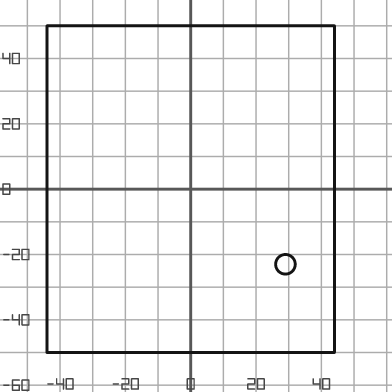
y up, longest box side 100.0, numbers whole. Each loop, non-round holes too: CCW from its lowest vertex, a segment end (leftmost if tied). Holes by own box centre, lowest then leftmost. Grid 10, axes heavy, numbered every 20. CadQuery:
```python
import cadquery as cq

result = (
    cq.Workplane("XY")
    .moveTo(-44.0, -50.0)
    .lineTo(44.0, -50.0)
    .lineTo(44.0, 50.0)
    .lineTo(-44.0, 50.0)
    .close()
    .moveTo(29.0, -23.0)
    .circle(3.0)
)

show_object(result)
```